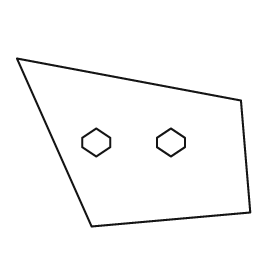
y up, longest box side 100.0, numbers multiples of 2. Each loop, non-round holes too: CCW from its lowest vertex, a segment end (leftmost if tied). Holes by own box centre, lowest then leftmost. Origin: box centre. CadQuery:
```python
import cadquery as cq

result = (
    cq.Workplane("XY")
    .moveTo(-18.0, -36.0)
    .lineTo(50.0, -30.0)
    .lineTo(46.0, 18.0)
    .lineTo(-50.0, 36.0)
    .close()
    .moveTo(-16.0, -6.0)
    .lineTo(-10.0, -2.0)
    .lineTo(-10.0, 2.0)
    .lineTo(-16.0, 6.0)
    .lineTo(-22.0, 2.0)
    .lineTo(-22.0, -2.0)
    .close()
    .moveTo(16.0, -6.0)
    .lineTo(22.0, -2.0)
    .lineTo(22.0, 2.0)
    .lineTo(16.0, 6.0)
    .lineTo(10.0, 2.0)
    .lineTo(10.0, -2.0)
    .close()
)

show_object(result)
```